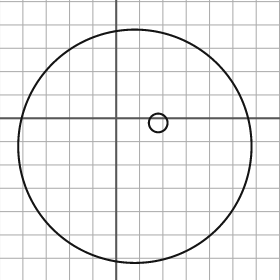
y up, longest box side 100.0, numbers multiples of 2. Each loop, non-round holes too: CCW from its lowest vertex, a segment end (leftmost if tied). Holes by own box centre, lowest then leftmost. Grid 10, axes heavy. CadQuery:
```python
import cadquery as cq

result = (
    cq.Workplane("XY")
    .moveTo(8.0, -12.0)
    .circle(50.0)
    .moveTo(18.0, -2.0)
    .circle(4.0)
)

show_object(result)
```